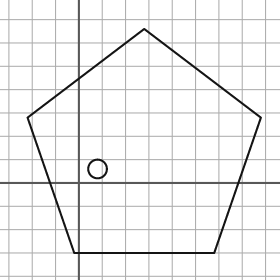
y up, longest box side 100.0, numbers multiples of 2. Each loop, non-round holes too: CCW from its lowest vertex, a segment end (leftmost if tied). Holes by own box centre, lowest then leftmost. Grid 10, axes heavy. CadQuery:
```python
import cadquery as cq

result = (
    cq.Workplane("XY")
    .moveTo(-2.0, -30.0)
    .lineTo(58.0, -30.0)
    .lineTo(78.0, 28.0)
    .lineTo(28.0, 66.0)
    .lineTo(-22.0, 28.0)
    .close()
    .moveTo(8.0, 6.0)
    .circle(4.0)
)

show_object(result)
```